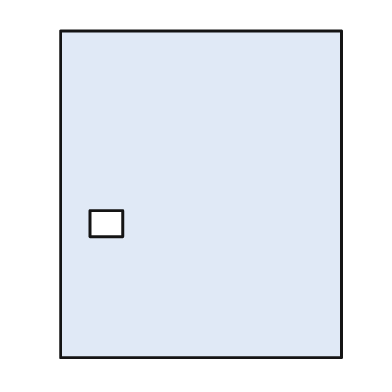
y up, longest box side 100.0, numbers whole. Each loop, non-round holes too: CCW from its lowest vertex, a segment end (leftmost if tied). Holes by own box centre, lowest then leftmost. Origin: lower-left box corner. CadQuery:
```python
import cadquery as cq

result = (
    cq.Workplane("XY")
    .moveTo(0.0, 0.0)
    .lineTo(86.0, 0.0)
    .lineTo(86.0, 100.0)
    .lineTo(0.0, 100.0)
    .close()
    .moveTo(9.0, 37.0)
    .lineTo(19.0, 37.0)
    .lineTo(19.0, 45.0)
    .lineTo(9.0, 45.0)
    .close()
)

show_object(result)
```